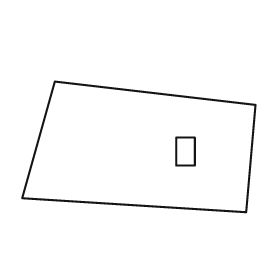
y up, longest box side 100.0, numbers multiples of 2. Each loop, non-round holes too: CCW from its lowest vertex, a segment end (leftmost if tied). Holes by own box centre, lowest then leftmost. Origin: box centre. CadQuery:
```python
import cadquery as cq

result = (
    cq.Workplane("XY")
    .moveTo(46.0, -28.0)
    .lineTo(50.0, 18.0)
    .lineTo(-36.0, 28.0)
    .lineTo(-50.0, -22.0)
    .close()
    .moveTo(16.0, -8.0)
    .lineTo(24.0, -8.0)
    .lineTo(24.0, 4.0)
    .lineTo(16.0, 4.0)
    .close()
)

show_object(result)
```